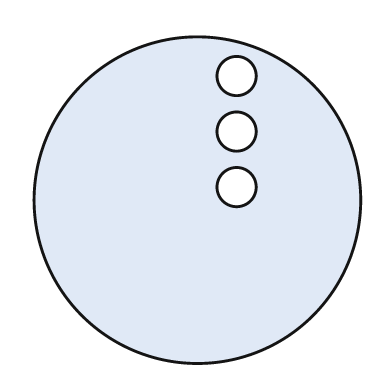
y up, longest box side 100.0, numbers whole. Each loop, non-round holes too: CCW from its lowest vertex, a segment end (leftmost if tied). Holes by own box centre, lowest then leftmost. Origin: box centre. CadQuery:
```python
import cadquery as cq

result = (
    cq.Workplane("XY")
    .moveTo(0.0, 0.0)
    .circle(50.0)
    .moveTo(12.0, 4.0)
    .circle(6.0)
    .moveTo(12.0, 21.0)
    .circle(6.0)
    .moveTo(12.0, 38.0)
    .circle(6.0)
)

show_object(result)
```